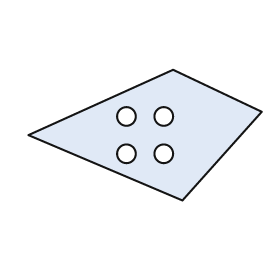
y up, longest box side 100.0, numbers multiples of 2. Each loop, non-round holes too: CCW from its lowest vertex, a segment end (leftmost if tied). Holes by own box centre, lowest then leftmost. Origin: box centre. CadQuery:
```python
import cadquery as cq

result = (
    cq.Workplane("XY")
    .moveTo(16.0, -28.0)
    .lineTo(50.0, 10.0)
    .lineTo(12.0, 28.0)
    .lineTo(-50.0, 0.0)
    .close()
    .moveTo(-8.0, -8.0)
    .circle(4.0)
    .moveTo(8.0, -8.0)
    .circle(4.0)
    .moveTo(-8.0, 8.0)
    .circle(4.0)
    .moveTo(8.0, 8.0)
    .circle(4.0)
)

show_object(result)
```